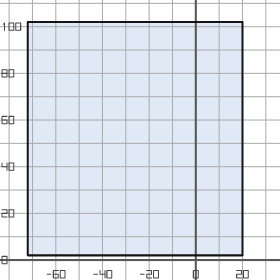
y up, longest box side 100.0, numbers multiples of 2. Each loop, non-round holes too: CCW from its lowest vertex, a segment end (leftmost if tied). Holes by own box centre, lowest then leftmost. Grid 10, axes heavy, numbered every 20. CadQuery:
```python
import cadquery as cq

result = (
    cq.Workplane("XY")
    .moveTo(-72.0, 2.0)
    .lineTo(20.0, 2.0)
    .lineTo(20.0, 102.0)
    .lineTo(-72.0, 102.0)
    .close()
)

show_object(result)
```